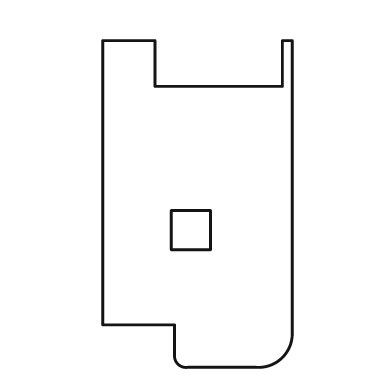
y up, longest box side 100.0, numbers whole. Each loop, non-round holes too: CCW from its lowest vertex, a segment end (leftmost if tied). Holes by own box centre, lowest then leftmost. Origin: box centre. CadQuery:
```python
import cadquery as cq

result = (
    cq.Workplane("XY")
    .moveTo(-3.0, -50.0)
    .lineTo(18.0, -50.0)
    .threePointArc((26.0, -47.0), (29.0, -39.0))
    .lineTo(29.0, 50.0)
    .lineTo(26.0, 50.0)
    .lineTo(26.0, 36.0)
    .lineTo(-13.0, 36.0)
    .lineTo(-13.0, 50.0)
    .lineTo(-29.0, 50.0)
    .lineTo(-29.0, -37.0)
    .lineTo(-7.0, -37.0)
    .lineTo(-7.0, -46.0)
    .threePointArc((-6.0, -49.0), (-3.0, -50.0))
    .close()
    .moveTo(-8.0, -14.0)
    .lineTo(4.0, -14.0)
    .lineTo(4.0, -2.0)
    .lineTo(-8.0, -2.0)
    .close()
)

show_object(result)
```